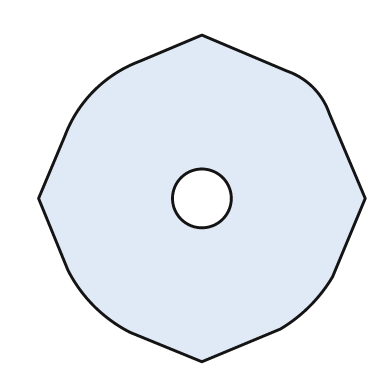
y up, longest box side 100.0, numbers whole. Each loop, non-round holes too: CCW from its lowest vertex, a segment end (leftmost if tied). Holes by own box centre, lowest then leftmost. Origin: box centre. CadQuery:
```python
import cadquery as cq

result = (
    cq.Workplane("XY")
    .moveTo(0.0, -50.0)
    .lineTo(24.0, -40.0)
    .threePointArc((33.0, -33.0), (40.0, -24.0))
    .lineTo(50.0, 0.0)
    .lineTo(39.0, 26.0)
    .threePointArc((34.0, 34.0), (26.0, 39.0))
    .lineTo(0.0, 50.0)
    .lineTo(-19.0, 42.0)
    .threePointArc((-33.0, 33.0), (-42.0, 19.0))
    .lineTo(-50.0, 0.0)
    .lineTo(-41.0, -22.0)
    .threePointArc((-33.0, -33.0), (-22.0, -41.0))
    .close()
    .moveTo(0.0, 0.0)
    .circle(9.0)
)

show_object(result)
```